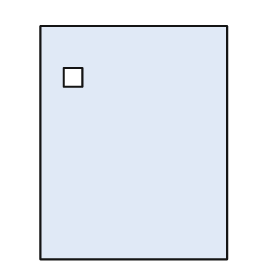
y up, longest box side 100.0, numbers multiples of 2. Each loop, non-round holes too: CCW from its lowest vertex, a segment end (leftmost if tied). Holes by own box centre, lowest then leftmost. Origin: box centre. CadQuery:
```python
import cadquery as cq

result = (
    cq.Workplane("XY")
    .moveTo(-40.0, -50.0)
    .lineTo(40.0, -50.0)
    .lineTo(40.0, 50.0)
    .lineTo(-40.0, 50.0)
    .close()
    .moveTo(-30.0, 24.0)
    .lineTo(-22.0, 24.0)
    .lineTo(-22.0, 32.0)
    .lineTo(-30.0, 32.0)
    .close()
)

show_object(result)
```